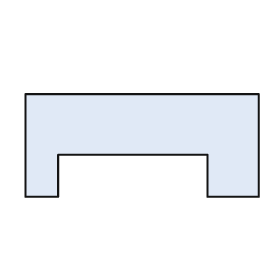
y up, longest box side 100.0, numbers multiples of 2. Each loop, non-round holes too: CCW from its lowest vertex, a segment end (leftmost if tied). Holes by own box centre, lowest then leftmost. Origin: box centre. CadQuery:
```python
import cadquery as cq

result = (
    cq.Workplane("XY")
    .moveTo(-50.0, -22.0)
    .lineTo(-36.0, -22.0)
    .lineTo(-36.0, -4.0)
    .lineTo(28.0, -4.0)
    .lineTo(28.0, -22.0)
    .lineTo(50.0, -22.0)
    .lineTo(50.0, 22.0)
    .lineTo(-50.0, 22.0)
    .close()
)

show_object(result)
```